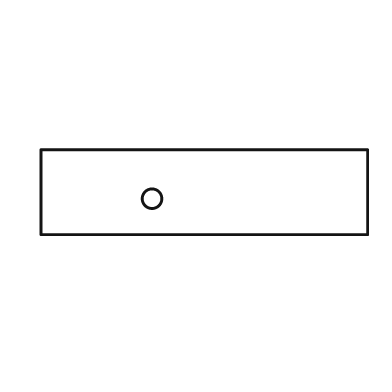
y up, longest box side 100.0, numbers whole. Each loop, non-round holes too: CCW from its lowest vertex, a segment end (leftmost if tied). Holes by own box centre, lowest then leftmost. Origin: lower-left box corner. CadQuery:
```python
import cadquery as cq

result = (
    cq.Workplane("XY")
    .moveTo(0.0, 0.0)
    .lineTo(100.0, 0.0)
    .lineTo(100.0, 26.0)
    .lineTo(0.0, 26.0)
    .close()
    .moveTo(34.0, 11.0)
    .circle(3.0)
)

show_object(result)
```